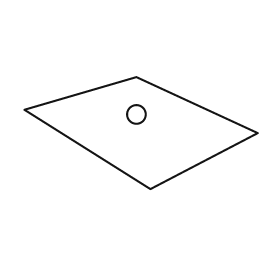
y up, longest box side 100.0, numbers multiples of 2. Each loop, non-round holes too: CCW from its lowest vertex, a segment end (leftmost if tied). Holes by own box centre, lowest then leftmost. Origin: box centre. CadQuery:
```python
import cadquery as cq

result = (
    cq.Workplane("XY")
    .moveTo(4.0, -24.0)
    .lineTo(50.0, 0.0)
    .lineTo(-2.0, 24.0)
    .lineTo(-50.0, 10.0)
    .close()
    .moveTo(-2.0, 8.0)
    .circle(4.0)
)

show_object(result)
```